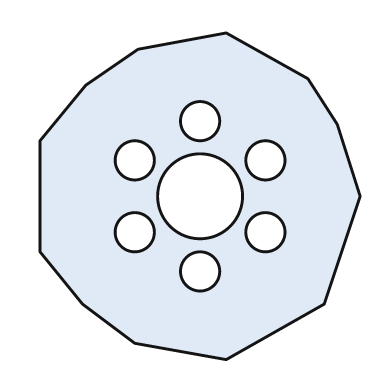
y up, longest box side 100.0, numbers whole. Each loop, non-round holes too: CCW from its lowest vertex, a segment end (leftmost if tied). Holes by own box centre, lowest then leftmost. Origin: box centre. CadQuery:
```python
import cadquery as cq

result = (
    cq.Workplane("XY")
    .moveTo(8.0, -50.0)
    .lineTo(38.0, -33.0)
    .lineTo(49.0, 0.0)
    .lineTo(42.0, 22.0)
    .lineTo(33.0, 36.0)
    .lineTo(8.0, 50.0)
    .lineTo(-19.0, 45.0)
    .lineTo(-35.0, 34.0)
    .lineTo(-49.0, 17.0)
    .lineTo(-49.0, -17.0)
    .lineTo(-36.0, -33.0)
    .lineTo(-20.0, -45.0)
    .close()
    .moveTo(0.0, -23.0)
    .circle(6.0)
    .moveTo(-20.0, -11.0)
    .circle(6.0)
    .moveTo(20.0, -11.0)
    .circle(6.0)
    .moveTo(0.0, 0.0)
    .circle(13.0)
    .moveTo(-20.0, 11.0)
    .circle(6.0)
    .moveTo(20.0, 11.0)
    .circle(6.0)
    .moveTo(0.0, 23.0)
    .circle(6.0)
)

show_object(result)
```